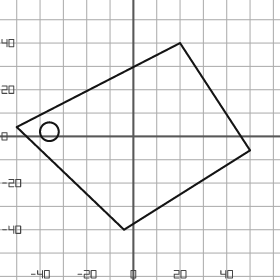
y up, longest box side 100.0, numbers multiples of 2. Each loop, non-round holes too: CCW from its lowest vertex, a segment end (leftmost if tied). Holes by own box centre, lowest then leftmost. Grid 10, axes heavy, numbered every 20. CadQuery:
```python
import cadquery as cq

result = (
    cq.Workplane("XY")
    .moveTo(-4.0, -40.0)
    .lineTo(50.0, -6.0)
    .lineTo(20.0, 40.0)
    .lineTo(-50.0, 4.0)
    .close()
    .moveTo(-36.0, 2.0)
    .circle(4.0)
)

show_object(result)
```